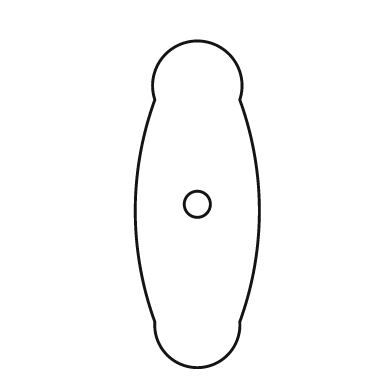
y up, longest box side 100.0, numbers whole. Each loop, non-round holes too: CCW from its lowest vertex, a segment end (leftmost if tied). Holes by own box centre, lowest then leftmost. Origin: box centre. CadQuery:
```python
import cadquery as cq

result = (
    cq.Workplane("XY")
    .moveTo(-13.0, -36.0)
    .threePointArc((0.0, -50.0), (13.0, -36.0))
    .threePointArc((19.0, -2.0), (13.0, 32.0))
    .threePointArc((0.0, 50.0), (-13.0, 32.0))
    .threePointArc((-19.0, -2.0), (-13.0, -36.0))
    .close()
    .moveTo(0.0, 0.0)
    .circle(4.0)
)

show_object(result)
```